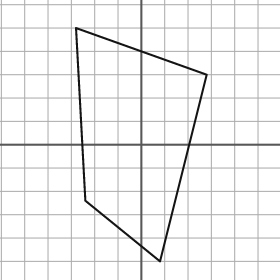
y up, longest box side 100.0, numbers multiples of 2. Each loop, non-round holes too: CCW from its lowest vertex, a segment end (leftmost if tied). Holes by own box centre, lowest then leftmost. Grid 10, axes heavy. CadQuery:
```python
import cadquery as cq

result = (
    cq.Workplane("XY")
    .moveTo(8.0, -50.0)
    .lineTo(28.0, 30.0)
    .lineTo(-28.0, 50.0)
    .lineTo(-24.0, -24.0)
    .close()
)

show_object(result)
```